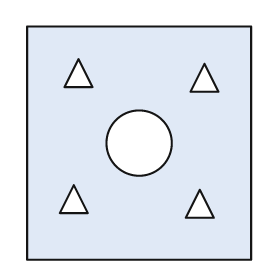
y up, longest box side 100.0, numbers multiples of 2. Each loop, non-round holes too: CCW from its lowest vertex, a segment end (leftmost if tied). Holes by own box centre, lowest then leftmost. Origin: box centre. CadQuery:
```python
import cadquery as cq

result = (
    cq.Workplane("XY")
    .moveTo(-48.0, -50.0)
    .lineTo(48.0, -50.0)
    .lineTo(48.0, 50.0)
    .lineTo(-48.0, 50.0)
    .close()
    .moveTo(20.0, -32.0)
    .lineTo(32.0, -32.0)
    .lineTo(26.0, -20.0)
    .close()
    .moveTo(-34.0, -30.0)
    .lineTo(-22.0, -30.0)
    .lineTo(-28.0, -18.0)
    .close()
    .moveTo(0.0, 0.0)
    .circle(14.0)
    .moveTo(22.0, 22.0)
    .lineTo(34.0, 22.0)
    .lineTo(28.0, 34.0)
    .close()
    .moveTo(-32.0, 24.0)
    .lineTo(-20.0, 24.0)
    .lineTo(-26.0, 36.0)
    .close()
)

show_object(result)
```